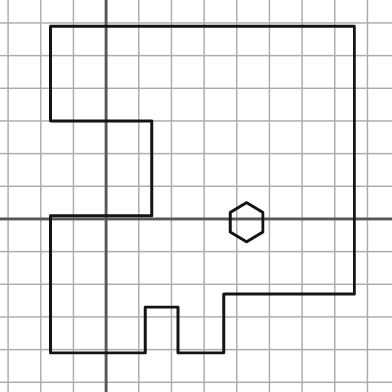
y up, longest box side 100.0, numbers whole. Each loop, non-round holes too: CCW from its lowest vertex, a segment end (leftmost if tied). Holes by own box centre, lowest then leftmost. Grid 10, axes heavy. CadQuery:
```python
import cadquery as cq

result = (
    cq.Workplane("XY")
    .moveTo(-17.0, -41.0)
    .lineTo(12.0, -41.0)
    .lineTo(12.0, -27.0)
    .lineTo(22.0, -27.0)
    .lineTo(22.0, -41.0)
    .lineTo(36.0, -41.0)
    .lineTo(36.0, -23.0)
    .lineTo(76.0, -23.0)
    .lineTo(76.0, 59.0)
    .lineTo(-17.0, 59.0)
    .lineTo(-17.0, 30.0)
    .lineTo(14.0, 30.0)
    .lineTo(14.0, 1.0)
    .lineTo(-17.0, 1.0)
    .close()
    .moveTo(43.0, -7.0)
    .lineTo(48.0, -4.0)
    .lineTo(48.0, 2.0)
    .lineTo(43.0, 5.0)
    .lineTo(38.0, 2.0)
    .lineTo(38.0, -4.0)
    .close()
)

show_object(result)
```